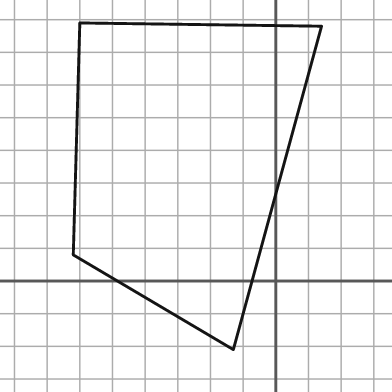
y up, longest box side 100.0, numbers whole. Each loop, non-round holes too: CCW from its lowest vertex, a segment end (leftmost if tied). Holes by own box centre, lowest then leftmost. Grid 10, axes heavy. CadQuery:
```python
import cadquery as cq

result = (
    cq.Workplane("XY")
    .moveTo(-13.0, -21.0)
    .lineTo(14.0, 78.0)
    .lineTo(-60.0, 79.0)
    .lineTo(-62.0, 8.0)
    .close()
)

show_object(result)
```